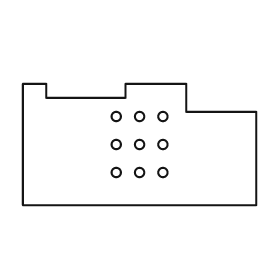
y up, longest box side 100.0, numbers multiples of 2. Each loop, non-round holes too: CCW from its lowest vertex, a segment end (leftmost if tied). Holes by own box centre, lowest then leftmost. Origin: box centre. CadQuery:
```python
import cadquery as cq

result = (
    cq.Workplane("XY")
    .moveTo(-50.0, -26.0)
    .lineTo(50.0, -26.0)
    .lineTo(50.0, 14.0)
    .lineTo(20.0, 14.0)
    .lineTo(20.0, 26.0)
    .lineTo(-6.0, 26.0)
    .lineTo(-6.0, 20.0)
    .lineTo(-40.0, 20.0)
    .lineTo(-40.0, 26.0)
    .lineTo(-50.0, 26.0)
    .close()
    .moveTo(-10.0, -12.0)
    .circle(2.0)
    .moveTo(0.0, -12.0)
    .circle(2.0)
    .moveTo(10.0, -12.0)
    .circle(2.0)
    .moveTo(-10.0, 0.0)
    .circle(2.0)
    .moveTo(0.0, 0.0)
    .circle(2.0)
    .moveTo(10.0, 0.0)
    .circle(2.0)
    .moveTo(-10.0, 12.0)
    .circle(2.0)
    .moveTo(0.0, 12.0)
    .circle(2.0)
    .moveTo(10.0, 12.0)
    .circle(2.0)
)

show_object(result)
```